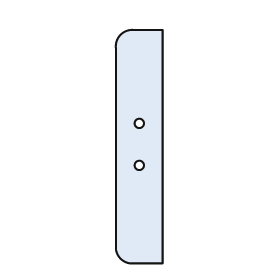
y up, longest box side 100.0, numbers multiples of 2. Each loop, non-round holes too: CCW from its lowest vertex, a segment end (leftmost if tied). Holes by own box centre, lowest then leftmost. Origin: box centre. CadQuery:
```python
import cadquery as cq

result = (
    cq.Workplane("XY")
    .moveTo(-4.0, -50.0)
    .lineTo(10.0, -50.0)
    .lineTo(10.0, 50.0)
    .lineTo(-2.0, 50.0)
    .threePointArc((-8.0, 48.0), (-10.0, 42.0))
    .lineTo(-10.0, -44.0)
    .threePointArc((-8.0, -48.0), (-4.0, -50.0))
    .close()
    .moveTo(0.0, -8.0)
    .circle(2.0)
    .moveTo(0.0, 10.0)
    .circle(2.0)
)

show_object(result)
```